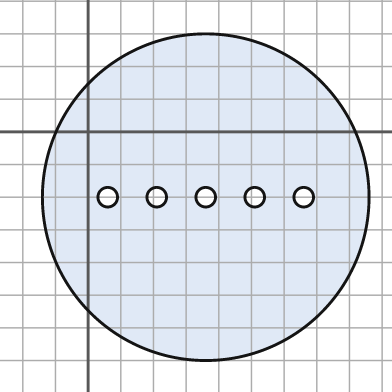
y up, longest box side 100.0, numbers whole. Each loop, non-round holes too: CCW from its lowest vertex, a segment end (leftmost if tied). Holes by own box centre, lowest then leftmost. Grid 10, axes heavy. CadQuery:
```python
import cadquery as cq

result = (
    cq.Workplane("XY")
    .moveTo(36.0, -20.0)
    .circle(50.0)
    .moveTo(6.0, -20.0)
    .circle(3.0)
    .moveTo(21.0, -20.0)
    .circle(3.0)
    .moveTo(36.0, -20.0)
    .circle(3.0)
    .moveTo(51.0, -20.0)
    .circle(3.0)
    .moveTo(66.0, -20.0)
    .circle(3.0)
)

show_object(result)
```